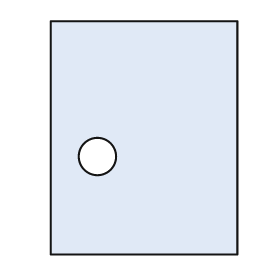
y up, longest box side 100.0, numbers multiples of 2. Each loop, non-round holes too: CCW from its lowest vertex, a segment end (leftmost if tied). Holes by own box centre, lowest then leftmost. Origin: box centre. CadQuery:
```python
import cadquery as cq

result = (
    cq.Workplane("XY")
    .moveTo(-40.0, -50.0)
    .lineTo(40.0, -50.0)
    .lineTo(40.0, 50.0)
    .lineTo(-40.0, 50.0)
    .close()
    .moveTo(-20.0, -8.0)
    .circle(8.0)
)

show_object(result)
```